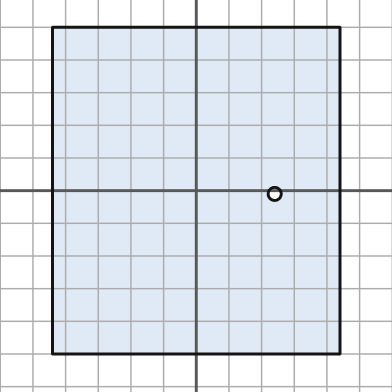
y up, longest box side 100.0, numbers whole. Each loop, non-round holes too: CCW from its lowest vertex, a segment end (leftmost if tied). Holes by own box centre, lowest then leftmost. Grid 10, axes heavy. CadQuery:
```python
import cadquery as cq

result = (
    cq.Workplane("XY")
    .moveTo(-44.0, -50.0)
    .lineTo(44.0, -50.0)
    .lineTo(44.0, 50.0)
    .lineTo(-44.0, 50.0)
    .close()
    .moveTo(24.0, -1.0)
    .circle(2.0)
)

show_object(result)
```